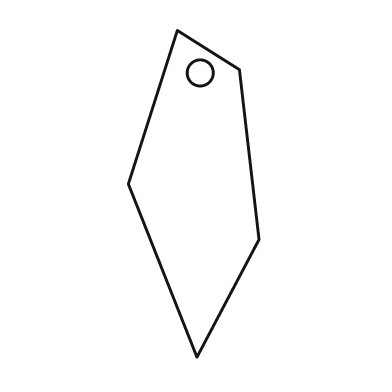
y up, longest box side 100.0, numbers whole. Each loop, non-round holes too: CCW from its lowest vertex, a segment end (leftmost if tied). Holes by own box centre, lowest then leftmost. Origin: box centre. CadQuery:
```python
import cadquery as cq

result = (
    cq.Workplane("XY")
    .moveTo(1.0, -50.0)
    .lineTo(20.0, -14.0)
    .lineTo(14.0, 38.0)
    .lineTo(-5.0, 50.0)
    .lineTo(-20.0, 3.0)
    .close()
    .moveTo(2.0, 37.0)
    .circle(4.0)
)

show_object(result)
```